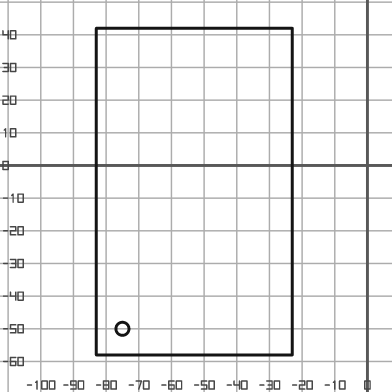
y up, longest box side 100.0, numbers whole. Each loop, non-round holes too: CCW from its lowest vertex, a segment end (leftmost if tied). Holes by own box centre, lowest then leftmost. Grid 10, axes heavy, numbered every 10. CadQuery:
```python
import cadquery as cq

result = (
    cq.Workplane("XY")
    .moveTo(-83.0, -58.0)
    .lineTo(-23.0, -58.0)
    .lineTo(-23.0, 42.0)
    .lineTo(-83.0, 42.0)
    .close()
    .moveTo(-75.0, -50.0)
    .circle(2.0)
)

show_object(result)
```